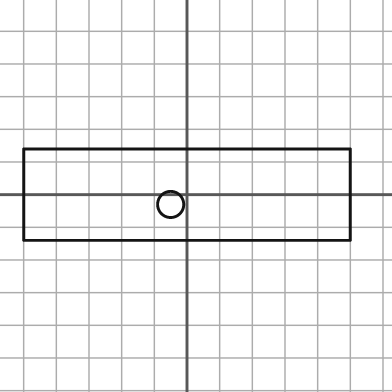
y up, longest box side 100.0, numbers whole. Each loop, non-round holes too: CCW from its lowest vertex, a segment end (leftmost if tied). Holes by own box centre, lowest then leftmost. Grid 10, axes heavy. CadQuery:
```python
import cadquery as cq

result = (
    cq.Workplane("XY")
    .moveTo(-50.0, -14.0)
    .lineTo(50.0, -14.0)
    .lineTo(50.0, 14.0)
    .lineTo(-50.0, 14.0)
    .close()
    .moveTo(-5.0, -3.0)
    .circle(4.0)
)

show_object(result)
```